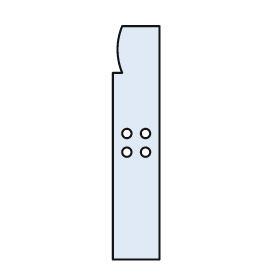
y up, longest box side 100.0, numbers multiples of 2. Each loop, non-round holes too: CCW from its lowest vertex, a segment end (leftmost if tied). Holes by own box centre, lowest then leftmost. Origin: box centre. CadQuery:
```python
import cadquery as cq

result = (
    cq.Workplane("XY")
    .moveTo(-10.0, -50.0)
    .lineTo(10.0, -50.0)
    .lineTo(10.0, 50.0)
    .lineTo(-6.0, 50.0)
    .threePointArc((-8.0, 40.0), (-6.0, 30.0))
    .lineTo(-10.0, 30.0)
    .close()
    .moveTo(-4.0, -4.0)
    .circle(2.0)
    .moveTo(4.0, -4.0)
    .circle(2.0)
    .moveTo(-4.0, 4.0)
    .circle(2.0)
    .moveTo(4.0, 4.0)
    .circle(2.0)
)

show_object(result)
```